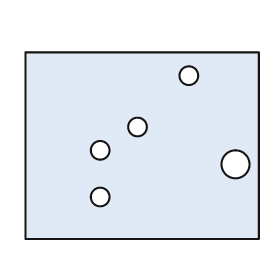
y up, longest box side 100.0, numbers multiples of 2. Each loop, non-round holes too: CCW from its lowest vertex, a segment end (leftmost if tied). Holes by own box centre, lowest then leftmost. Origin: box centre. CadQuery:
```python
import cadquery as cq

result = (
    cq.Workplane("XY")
    .moveTo(-50.0, -40.0)
    .lineTo(50.0, -40.0)
    .lineTo(50.0, 40.0)
    .lineTo(-50.0, 40.0)
    .close()
    .moveTo(-18.0, -22.0)
    .circle(4.0)
    .moveTo(40.0, -8.0)
    .circle(6.0)
    .moveTo(-18.0, -2.0)
    .circle(4.0)
    .moveTo(-2.0, 8.0)
    .circle(4.0)
    .moveTo(20.0, 30.0)
    .circle(4.0)
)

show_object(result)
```